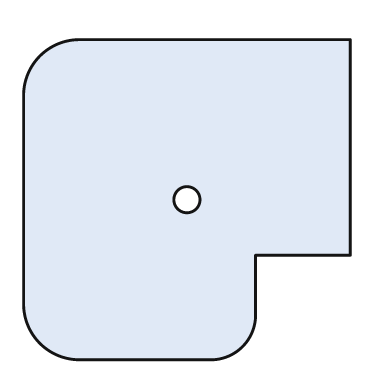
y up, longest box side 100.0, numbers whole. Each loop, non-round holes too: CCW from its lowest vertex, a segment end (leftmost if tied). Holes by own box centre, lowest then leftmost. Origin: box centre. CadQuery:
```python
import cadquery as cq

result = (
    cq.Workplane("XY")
    .moveTo(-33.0, -49.0)
    .lineTo(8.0, -49.0)
    .threePointArc((17.0, -45.0), (21.0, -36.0))
    .lineTo(21.0, -17.0)
    .lineTo(50.0, -17.0)
    .lineTo(50.0, 49.0)
    .lineTo(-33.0, 49.0)
    .threePointArc((-45.0, 44.0), (-50.0, 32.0))
    .lineTo(-50.0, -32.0)
    .threePointArc((-45.0, -44.0), (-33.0, -49.0))
    .close()
    .moveTo(0.0, 0.0)
    .circle(4.0)
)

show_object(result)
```